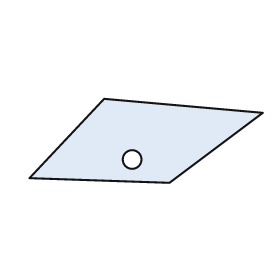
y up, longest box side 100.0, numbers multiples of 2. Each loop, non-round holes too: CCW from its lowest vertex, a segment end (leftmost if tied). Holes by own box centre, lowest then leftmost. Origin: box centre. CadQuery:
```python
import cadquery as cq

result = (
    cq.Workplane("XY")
    .moveTo(10.0, -18.0)
    .lineTo(50.0, 12.0)
    .lineTo(-18.0, 18.0)
    .lineTo(-50.0, -16.0)
    .close()
    .moveTo(-6.0, -8.0)
    .circle(4.0)
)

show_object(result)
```